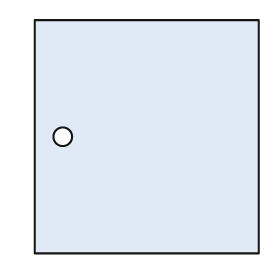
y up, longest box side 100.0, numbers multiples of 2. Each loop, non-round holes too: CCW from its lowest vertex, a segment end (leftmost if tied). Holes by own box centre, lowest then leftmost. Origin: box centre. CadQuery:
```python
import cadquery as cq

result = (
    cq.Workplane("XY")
    .moveTo(-48.0, -50.0)
    .lineTo(48.0, -50.0)
    .lineTo(48.0, 50.0)
    .lineTo(-48.0, 50.0)
    .close()
    .moveTo(-36.0, 0.0)
    .circle(4.0)
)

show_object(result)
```